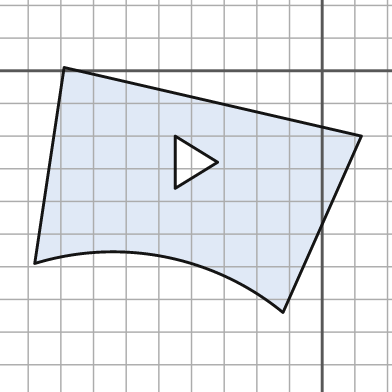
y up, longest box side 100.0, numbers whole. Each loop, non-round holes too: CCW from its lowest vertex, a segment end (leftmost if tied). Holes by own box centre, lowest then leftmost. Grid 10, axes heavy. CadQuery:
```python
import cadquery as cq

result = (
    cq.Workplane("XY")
    .moveTo(-12.0, -74.0)
    .lineTo(12.0, -20.0)
    .lineTo(-79.0, 1.0)
    .lineTo(-88.0, -59.0)
    .threePointArc((-48.0, -57.0), (-12.0, -74.0))
    .close()
    .moveTo(-45.0, -36.0)
    .lineTo(-32.0, -28.0)
    .lineTo(-45.0, -20.0)
    .close()
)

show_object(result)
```